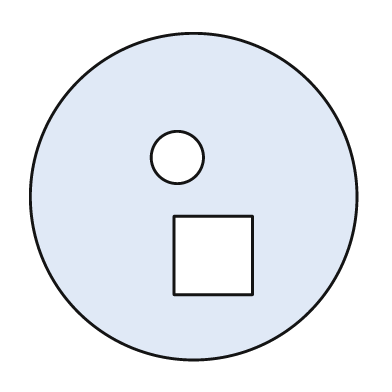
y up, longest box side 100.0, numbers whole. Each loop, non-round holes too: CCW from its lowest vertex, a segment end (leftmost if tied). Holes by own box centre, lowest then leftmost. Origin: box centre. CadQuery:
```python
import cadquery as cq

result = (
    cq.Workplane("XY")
    .moveTo(0.0, 0.0)
    .circle(50.0)
    .moveTo(-6.0, -30.0)
    .lineTo(18.0, -30.0)
    .lineTo(18.0, -6.0)
    .lineTo(-6.0, -6.0)
    .close()
    .moveTo(-5.0, 12.0)
    .circle(8.0)
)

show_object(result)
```